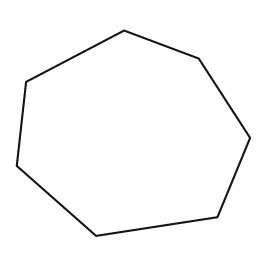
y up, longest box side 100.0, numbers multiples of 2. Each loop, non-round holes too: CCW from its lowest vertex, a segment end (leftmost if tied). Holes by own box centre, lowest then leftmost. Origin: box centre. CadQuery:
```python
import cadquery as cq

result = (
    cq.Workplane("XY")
    .moveTo(-16.0, -44.0)
    .lineTo(36.0, -36.0)
    .lineTo(50.0, -2.0)
    .lineTo(28.0, 32.0)
    .lineTo(-4.0, 44.0)
    .lineTo(-46.0, 22.0)
    .lineTo(-50.0, -14.0)
    .close()
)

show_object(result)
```